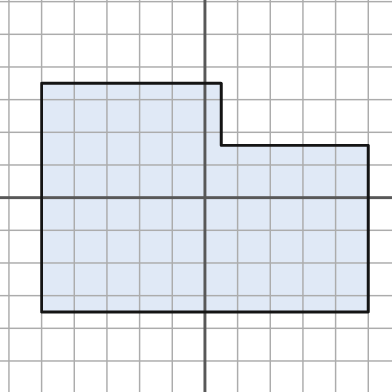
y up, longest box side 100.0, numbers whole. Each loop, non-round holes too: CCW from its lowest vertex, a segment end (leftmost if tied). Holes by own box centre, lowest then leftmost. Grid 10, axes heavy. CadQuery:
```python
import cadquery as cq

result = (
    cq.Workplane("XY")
    .moveTo(-50.0, -35.0)
    .lineTo(50.0, -35.0)
    .lineTo(50.0, 16.0)
    .lineTo(5.0, 16.0)
    .lineTo(5.0, 35.0)
    .lineTo(-50.0, 35.0)
    .close()
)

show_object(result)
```